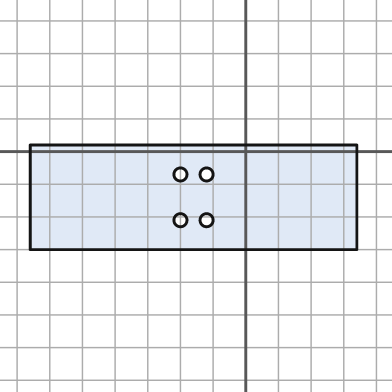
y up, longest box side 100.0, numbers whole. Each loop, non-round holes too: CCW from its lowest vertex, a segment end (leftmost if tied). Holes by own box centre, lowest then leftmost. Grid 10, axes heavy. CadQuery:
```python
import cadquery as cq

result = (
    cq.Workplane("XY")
    .moveTo(-66.0, -30.0)
    .lineTo(34.0, -30.0)
    .lineTo(34.0, 2.0)
    .lineTo(-66.0, 2.0)
    .close()
    .moveTo(-20.0, -21.0)
    .circle(2.0)
    .moveTo(-12.0, -21.0)
    .circle(2.0)
    .moveTo(-20.0, -7.0)
    .circle(2.0)
    .moveTo(-12.0, -7.0)
    .circle(2.0)
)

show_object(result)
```